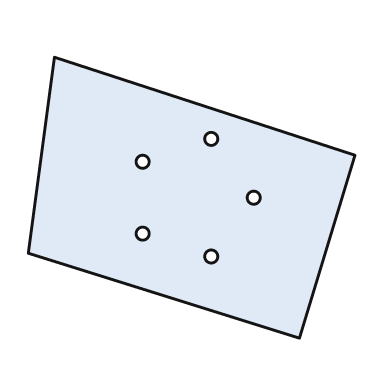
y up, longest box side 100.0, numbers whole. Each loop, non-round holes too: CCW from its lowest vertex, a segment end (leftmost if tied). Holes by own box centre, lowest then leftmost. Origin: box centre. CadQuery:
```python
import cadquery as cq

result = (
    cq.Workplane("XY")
    .moveTo(33.0, -43.0)
    .lineTo(50.0, 13.0)
    .lineTo(-42.0, 43.0)
    .lineTo(-50.0, -17.0)
    .close()
    .moveTo(6.0, -18.0)
    .circle(2.0)
    .moveTo(-15.0, -11.0)
    .circle(2.0)
    .moveTo(19.0, 0.0)
    .circle(2.0)
    .moveTo(-15.0, 11.0)
    .circle(2.0)
    .moveTo(6.0, 18.0)
    .circle(2.0)
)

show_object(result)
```